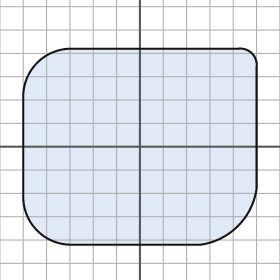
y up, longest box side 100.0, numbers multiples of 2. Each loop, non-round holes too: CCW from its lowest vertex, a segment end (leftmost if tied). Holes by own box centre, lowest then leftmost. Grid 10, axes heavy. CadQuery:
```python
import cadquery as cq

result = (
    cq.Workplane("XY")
    .moveTo(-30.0, -42.0)
    .lineTo(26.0, -42.0)
    .threePointArc((42.0, -34.0), (50.0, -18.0))
    .lineTo(50.0, 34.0)
    .threePointArc((48.0, 40.0), (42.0, 42.0))
    .lineTo(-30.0, 42.0)
    .threePointArc((-44.0, 36.0), (-50.0, 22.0))
    .lineTo(-50.0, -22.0)
    .threePointArc((-44.0, -36.0), (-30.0, -42.0))
    .close()
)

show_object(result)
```